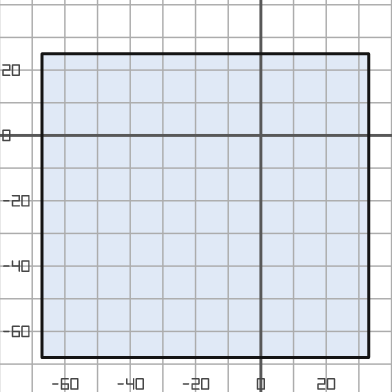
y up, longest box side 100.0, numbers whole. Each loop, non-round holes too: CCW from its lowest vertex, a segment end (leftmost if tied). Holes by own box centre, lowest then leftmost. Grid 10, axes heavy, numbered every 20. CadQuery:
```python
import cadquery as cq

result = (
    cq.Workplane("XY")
    .moveTo(-67.0, -68.0)
    .lineTo(33.0, -68.0)
    .lineTo(33.0, 25.0)
    .lineTo(-67.0, 25.0)
    .close()
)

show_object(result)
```